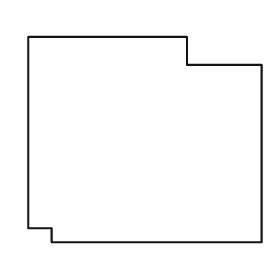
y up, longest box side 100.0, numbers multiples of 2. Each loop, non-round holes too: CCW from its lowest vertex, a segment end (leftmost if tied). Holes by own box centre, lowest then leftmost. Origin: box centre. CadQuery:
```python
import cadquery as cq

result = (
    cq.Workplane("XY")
    .moveTo(-40.0, -44.0)
    .lineTo(50.0, -44.0)
    .lineTo(50.0, 32.0)
    .lineTo(18.0, 32.0)
    .lineTo(18.0, 44.0)
    .lineTo(-50.0, 44.0)
    .lineTo(-50.0, -38.0)
    .lineTo(-40.0, -38.0)
    .close()
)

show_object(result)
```